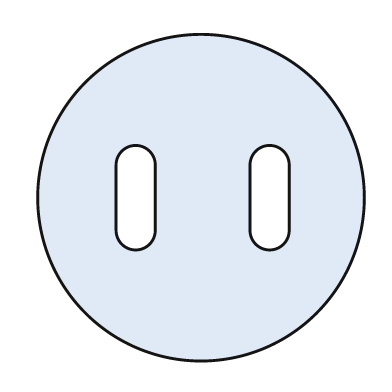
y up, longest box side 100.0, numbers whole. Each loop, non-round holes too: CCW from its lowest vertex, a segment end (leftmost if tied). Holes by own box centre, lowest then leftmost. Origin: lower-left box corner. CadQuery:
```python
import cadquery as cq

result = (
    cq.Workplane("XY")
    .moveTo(50.0, 50.0)
    .circle(50.0)
    .moveTo(24.0, 40.0)
    .threePointArc((30.0, 34.0), (36.0, 40.0))
    .lineTo(36.0, 60.0)
    .threePointArc((30.0, 66.0), (24.0, 60.0))
    .close()
    .moveTo(65.0, 40.0)
    .threePointArc((71.0, 34.0), (77.0, 40.0))
    .lineTo(77.0, 60.0)
    .threePointArc((71.0, 66.0), (65.0, 60.0))
    .close()
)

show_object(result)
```